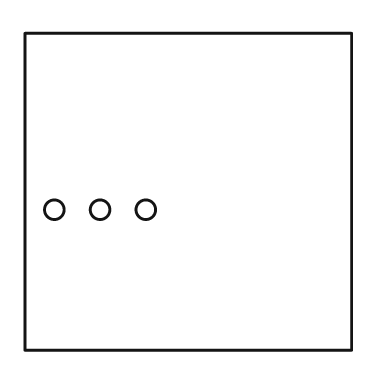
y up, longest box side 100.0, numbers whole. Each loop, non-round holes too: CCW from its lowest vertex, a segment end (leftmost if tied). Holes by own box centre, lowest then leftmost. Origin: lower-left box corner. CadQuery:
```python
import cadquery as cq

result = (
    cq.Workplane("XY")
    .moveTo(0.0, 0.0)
    .lineTo(100.0, 0.0)
    .lineTo(100.0, 97.0)
    .lineTo(0.0, 97.0)
    .close()
    .moveTo(9.0, 43.0)
    .circle(3.0)
    .moveTo(23.0, 43.0)
    .circle(3.0)
    .moveTo(37.0, 43.0)
    .circle(3.0)
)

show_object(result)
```